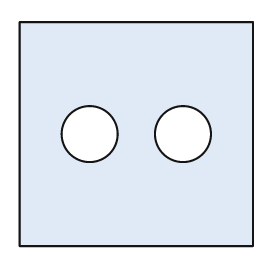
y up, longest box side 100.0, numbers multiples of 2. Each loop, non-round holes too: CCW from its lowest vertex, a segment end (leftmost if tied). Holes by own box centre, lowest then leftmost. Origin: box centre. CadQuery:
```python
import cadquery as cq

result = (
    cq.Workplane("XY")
    .moveTo(-50.0, -48.0)
    .lineTo(50.0, -48.0)
    .lineTo(50.0, 48.0)
    .lineTo(-50.0, 48.0)
    .close()
    .moveTo(-20.0, 0.0)
    .circle(12.0)
    .moveTo(20.0, 0.0)
    .circle(12.0)
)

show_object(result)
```